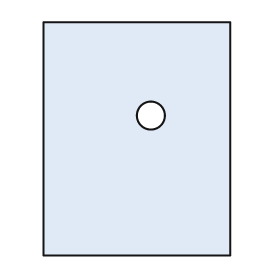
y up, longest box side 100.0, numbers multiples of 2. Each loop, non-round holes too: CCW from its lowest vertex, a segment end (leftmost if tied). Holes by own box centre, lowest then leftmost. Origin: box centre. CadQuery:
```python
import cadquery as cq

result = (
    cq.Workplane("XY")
    .moveTo(-40.0, -50.0)
    .lineTo(40.0, -50.0)
    .lineTo(40.0, 50.0)
    .lineTo(-40.0, 50.0)
    .close()
    .moveTo(6.0, 10.0)
    .circle(6.0)
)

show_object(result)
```